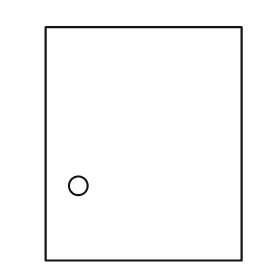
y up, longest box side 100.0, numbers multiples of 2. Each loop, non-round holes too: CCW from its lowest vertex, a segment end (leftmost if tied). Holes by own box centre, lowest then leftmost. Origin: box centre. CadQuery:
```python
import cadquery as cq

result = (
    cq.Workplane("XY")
    .moveTo(-42.0, -50.0)
    .lineTo(42.0, -50.0)
    .lineTo(42.0, 50.0)
    .lineTo(-42.0, 50.0)
    .close()
    .moveTo(-28.0, -18.0)
    .circle(4.0)
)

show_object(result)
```